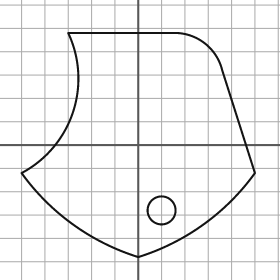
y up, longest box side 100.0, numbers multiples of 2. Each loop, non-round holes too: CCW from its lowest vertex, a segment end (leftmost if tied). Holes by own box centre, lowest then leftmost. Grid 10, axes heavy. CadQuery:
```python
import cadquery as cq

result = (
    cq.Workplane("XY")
    .moveTo(0.0, -48.0)
    .threePointArc((28.0, -34.0), (50.0, -12.0))
    .lineTo(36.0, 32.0)
    .threePointArc((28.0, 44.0), (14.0, 48.0))
    .lineTo(-30.0, 48.0)
    .threePointArc((-28.0, 14.0), (-50.0, -12.0))
    .threePointArc((-28.0, -34.0), (0.0, -48.0))
    .close()
    .moveTo(10.0, -28.0)
    .circle(6.0)
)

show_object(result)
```